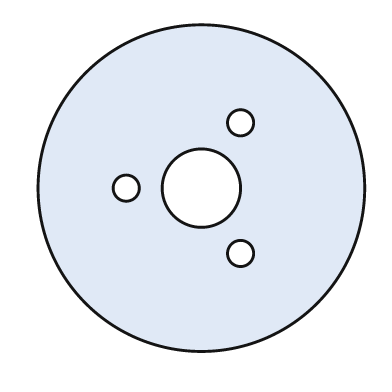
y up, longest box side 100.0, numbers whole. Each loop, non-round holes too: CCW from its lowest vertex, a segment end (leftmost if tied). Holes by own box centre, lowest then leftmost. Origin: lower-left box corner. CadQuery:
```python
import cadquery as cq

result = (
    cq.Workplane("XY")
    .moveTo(50.0, 50.0)
    .circle(50.0)
    .moveTo(62.0, 30.0)
    .circle(4.0)
    .moveTo(27.0, 50.0)
    .circle(4.0)
    .moveTo(50.0, 50.0)
    .circle(12.0)
    .moveTo(62.0, 70.0)
    .circle(4.0)
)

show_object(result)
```